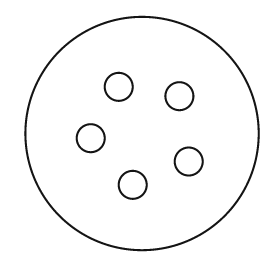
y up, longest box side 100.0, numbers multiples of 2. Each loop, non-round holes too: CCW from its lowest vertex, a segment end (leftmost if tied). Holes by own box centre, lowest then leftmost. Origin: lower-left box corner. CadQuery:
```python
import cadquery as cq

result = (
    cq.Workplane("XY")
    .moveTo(50.0, 50.0)
    .circle(50.0)
    .moveTo(46.0, 28.0)
    .circle(6.0)
    .moveTo(70.0, 38.0)
    .circle(6.0)
    .moveTo(28.0, 48.0)
    .circle(6.0)
    .moveTo(66.0, 66.0)
    .circle(6.0)
    .moveTo(40.0, 70.0)
    .circle(6.0)
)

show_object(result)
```